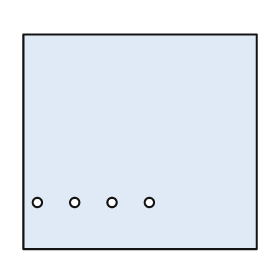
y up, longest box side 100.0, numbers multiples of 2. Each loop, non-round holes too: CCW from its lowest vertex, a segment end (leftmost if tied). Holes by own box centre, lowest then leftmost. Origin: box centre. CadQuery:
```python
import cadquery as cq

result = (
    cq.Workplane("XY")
    .moveTo(-50.0, -46.0)
    .lineTo(50.0, -46.0)
    .lineTo(50.0, 46.0)
    .lineTo(-50.0, 46.0)
    .close()
    .moveTo(-44.0, -26.0)
    .circle(2.0)
    .moveTo(-28.0, -26.0)
    .circle(2.0)
    .moveTo(-12.0, -26.0)
    .circle(2.0)
    .moveTo(4.0, -26.0)
    .circle(2.0)
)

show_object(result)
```